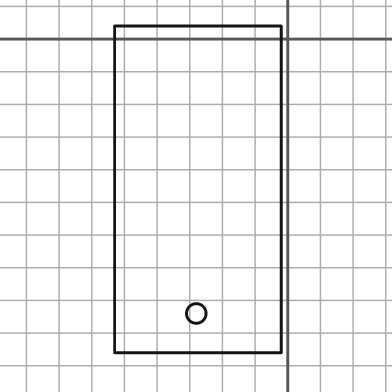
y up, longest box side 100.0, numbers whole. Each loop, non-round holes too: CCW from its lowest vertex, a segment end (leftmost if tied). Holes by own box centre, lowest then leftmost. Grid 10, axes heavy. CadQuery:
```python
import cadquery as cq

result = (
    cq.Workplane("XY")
    .moveTo(-53.0, -96.0)
    .lineTo(-2.0, -96.0)
    .lineTo(-2.0, 4.0)
    .lineTo(-53.0, 4.0)
    .close()
    .moveTo(-28.0, -84.0)
    .circle(3.0)
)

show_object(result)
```